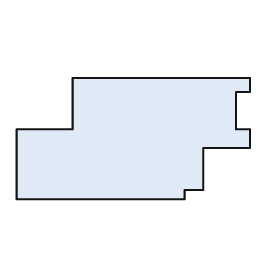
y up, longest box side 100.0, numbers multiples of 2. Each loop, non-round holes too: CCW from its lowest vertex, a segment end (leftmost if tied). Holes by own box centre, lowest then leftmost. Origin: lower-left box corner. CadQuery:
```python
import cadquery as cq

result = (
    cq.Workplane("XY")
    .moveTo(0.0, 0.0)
    .lineTo(72.0, 0.0)
    .lineTo(72.0, 4.0)
    .lineTo(80.0, 4.0)
    .lineTo(80.0, 22.0)
    .lineTo(100.0, 22.0)
    .lineTo(100.0, 30.0)
    .lineTo(94.0, 30.0)
    .lineTo(94.0, 46.0)
    .lineTo(100.0, 46.0)
    .lineTo(100.0, 52.0)
    .lineTo(24.0, 52.0)
    .lineTo(24.0, 30.0)
    .lineTo(0.0, 30.0)
    .close()
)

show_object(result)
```